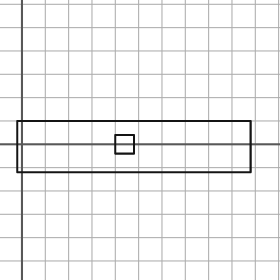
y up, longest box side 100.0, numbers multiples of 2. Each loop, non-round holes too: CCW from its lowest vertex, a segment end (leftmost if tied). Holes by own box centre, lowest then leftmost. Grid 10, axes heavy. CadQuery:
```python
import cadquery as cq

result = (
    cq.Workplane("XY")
    .moveTo(-2.0, -12.0)
    .lineTo(98.0, -12.0)
    .lineTo(98.0, 10.0)
    .lineTo(-2.0, 10.0)
    .close()
    .moveTo(40.0, -4.0)
    .lineTo(48.0, -4.0)
    .lineTo(48.0, 4.0)
    .lineTo(40.0, 4.0)
    .close()
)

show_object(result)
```